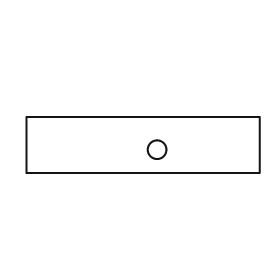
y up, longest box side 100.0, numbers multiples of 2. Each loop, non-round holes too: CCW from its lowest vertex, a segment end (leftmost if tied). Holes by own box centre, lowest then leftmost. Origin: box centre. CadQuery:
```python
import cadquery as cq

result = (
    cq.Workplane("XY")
    .moveTo(-50.0, -12.0)
    .lineTo(50.0, -12.0)
    .lineTo(50.0, 12.0)
    .lineTo(-50.0, 12.0)
    .close()
    .moveTo(6.0, -2.0)
    .circle(4.0)
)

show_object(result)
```